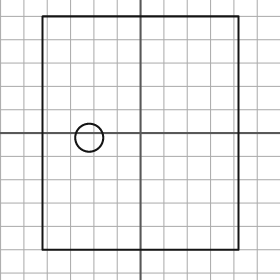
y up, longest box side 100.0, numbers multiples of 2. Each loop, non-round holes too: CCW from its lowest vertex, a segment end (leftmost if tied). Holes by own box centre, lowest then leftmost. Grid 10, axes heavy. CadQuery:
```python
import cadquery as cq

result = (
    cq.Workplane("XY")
    .moveTo(-42.0, -50.0)
    .lineTo(42.0, -50.0)
    .lineTo(42.0, 50.0)
    .lineTo(-42.0, 50.0)
    .close()
    .moveTo(-22.0, -2.0)
    .circle(6.0)
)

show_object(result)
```